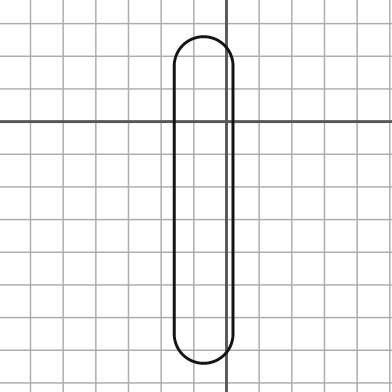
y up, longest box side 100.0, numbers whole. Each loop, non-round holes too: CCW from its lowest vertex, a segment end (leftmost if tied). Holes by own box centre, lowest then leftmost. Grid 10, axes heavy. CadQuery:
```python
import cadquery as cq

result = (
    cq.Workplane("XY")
    .moveTo(-16.0, -65.0)
    .threePointArc((-7.0, -74.0), (2.0, -65.0))
    .lineTo(2.0, 17.0)
    .threePointArc((-7.0, 26.0), (-16.0, 17.0))
    .close()
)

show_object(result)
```